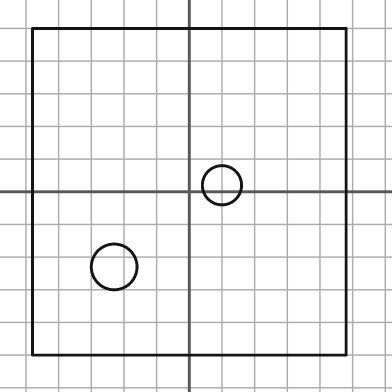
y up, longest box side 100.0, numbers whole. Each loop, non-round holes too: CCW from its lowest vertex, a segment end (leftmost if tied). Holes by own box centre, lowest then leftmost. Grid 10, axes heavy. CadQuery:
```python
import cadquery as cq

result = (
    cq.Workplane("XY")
    .moveTo(-48.0, -50.0)
    .lineTo(48.0, -50.0)
    .lineTo(48.0, 50.0)
    .lineTo(-48.0, 50.0)
    .close()
    .moveTo(-23.0, -23.0)
    .circle(7.0)
    .moveTo(10.0, 2.0)
    .circle(6.0)
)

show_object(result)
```